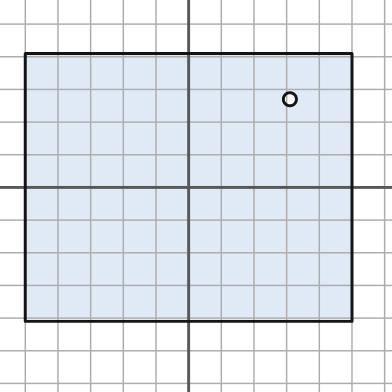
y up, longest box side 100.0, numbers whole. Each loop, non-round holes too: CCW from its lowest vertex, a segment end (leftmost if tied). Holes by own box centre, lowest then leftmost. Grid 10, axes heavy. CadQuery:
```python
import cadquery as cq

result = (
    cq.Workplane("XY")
    .moveTo(-50.0, -41.0)
    .lineTo(50.0, -41.0)
    .lineTo(50.0, 41.0)
    .lineTo(-50.0, 41.0)
    .close()
    .moveTo(31.0, 27.0)
    .circle(2.0)
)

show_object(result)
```